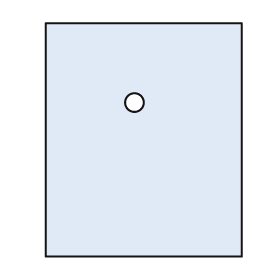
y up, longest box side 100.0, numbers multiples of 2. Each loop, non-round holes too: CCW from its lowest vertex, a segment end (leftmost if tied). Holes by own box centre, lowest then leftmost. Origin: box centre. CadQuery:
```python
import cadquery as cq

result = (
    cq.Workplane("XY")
    .moveTo(-42.0, -50.0)
    .lineTo(42.0, -50.0)
    .lineTo(42.0, 50.0)
    .lineTo(-42.0, 50.0)
    .close()
    .moveTo(-4.0, 16.0)
    .circle(4.0)
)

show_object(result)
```